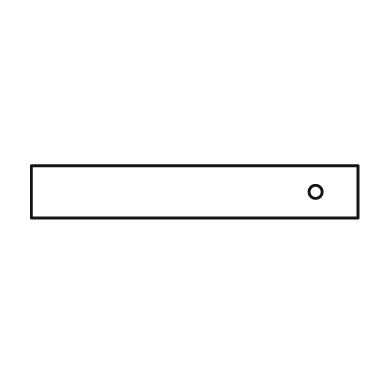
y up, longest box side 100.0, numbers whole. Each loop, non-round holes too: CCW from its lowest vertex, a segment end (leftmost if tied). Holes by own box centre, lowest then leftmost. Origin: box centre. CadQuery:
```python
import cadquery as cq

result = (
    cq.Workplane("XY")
    .moveTo(-50.0, -8.0)
    .lineTo(50.0, -8.0)
    .lineTo(50.0, 8.0)
    .lineTo(-50.0, 8.0)
    .close()
    .moveTo(37.0, 0.0)
    .circle(2.0)
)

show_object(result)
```